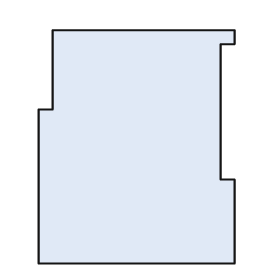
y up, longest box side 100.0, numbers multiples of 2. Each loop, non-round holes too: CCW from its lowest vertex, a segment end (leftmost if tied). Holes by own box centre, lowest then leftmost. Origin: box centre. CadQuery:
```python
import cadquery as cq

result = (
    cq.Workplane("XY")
    .moveTo(-42.0, -50.0)
    .lineTo(42.0, -50.0)
    .lineTo(42.0, -14.0)
    .lineTo(36.0, -14.0)
    .lineTo(36.0, 44.0)
    .lineTo(42.0, 44.0)
    .lineTo(42.0, 50.0)
    .lineTo(-36.0, 50.0)
    .lineTo(-36.0, 16.0)
    .lineTo(-42.0, 16.0)
    .close()
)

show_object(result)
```